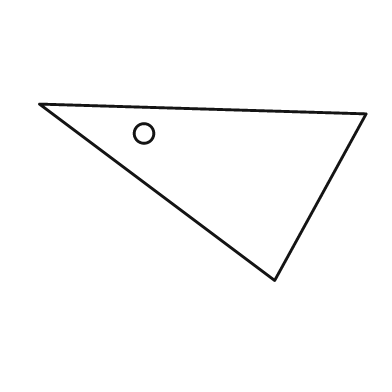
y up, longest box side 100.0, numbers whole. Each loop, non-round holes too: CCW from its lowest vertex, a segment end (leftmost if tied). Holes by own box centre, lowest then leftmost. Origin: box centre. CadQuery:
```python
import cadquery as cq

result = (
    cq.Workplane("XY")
    .moveTo(22.0, -27.0)
    .lineTo(50.0, 24.0)
    .lineTo(-50.0, 27.0)
    .close()
    .moveTo(-18.0, 18.0)
    .circle(3.0)
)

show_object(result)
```